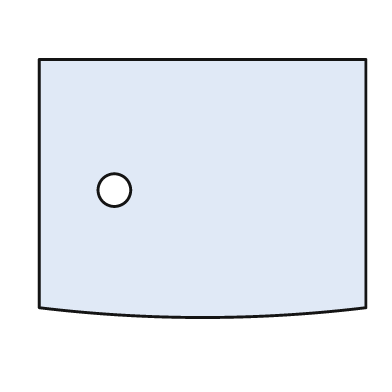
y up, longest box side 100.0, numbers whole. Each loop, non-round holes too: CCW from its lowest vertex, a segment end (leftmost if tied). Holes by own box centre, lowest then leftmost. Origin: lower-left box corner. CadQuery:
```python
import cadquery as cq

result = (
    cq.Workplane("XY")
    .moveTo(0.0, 3.0)
    .threePointArc((50.0, 0.0), (100.0, 3.0))
    .lineTo(100.0, 79.0)
    .lineTo(0.0, 79.0)
    .close()
    .moveTo(23.0, 39.0)
    .circle(5.0)
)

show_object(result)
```